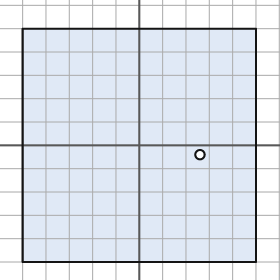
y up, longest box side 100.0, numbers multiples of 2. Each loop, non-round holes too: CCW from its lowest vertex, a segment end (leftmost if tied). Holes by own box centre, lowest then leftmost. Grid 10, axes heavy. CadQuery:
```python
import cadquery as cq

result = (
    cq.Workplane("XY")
    .moveTo(-50.0, -50.0)
    .lineTo(50.0, -50.0)
    .lineTo(50.0, 50.0)
    .lineTo(-50.0, 50.0)
    .close()
    .moveTo(26.0, -4.0)
    .circle(2.0)
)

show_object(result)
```